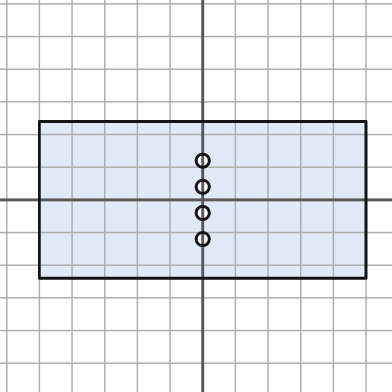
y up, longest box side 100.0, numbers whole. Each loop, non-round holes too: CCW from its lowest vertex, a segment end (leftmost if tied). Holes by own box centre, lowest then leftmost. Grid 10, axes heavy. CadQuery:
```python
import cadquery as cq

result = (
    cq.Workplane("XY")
    .moveTo(-50.0, -24.0)
    .lineTo(50.0, -24.0)
    .lineTo(50.0, 24.0)
    .lineTo(-50.0, 24.0)
    .close()
    .moveTo(0.0, -12.0)
    .circle(2.0)
    .moveTo(0.0, -4.0)
    .circle(2.0)
    .moveTo(0.0, 4.0)
    .circle(2.0)
    .moveTo(0.0, 12.0)
    .circle(2.0)
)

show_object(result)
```